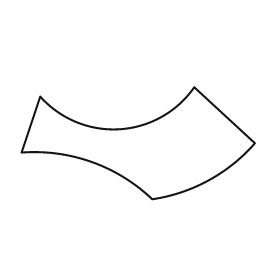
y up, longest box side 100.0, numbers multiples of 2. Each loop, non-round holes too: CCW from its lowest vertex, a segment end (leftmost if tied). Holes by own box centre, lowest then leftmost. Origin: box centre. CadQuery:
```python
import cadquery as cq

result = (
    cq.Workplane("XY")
    .moveTo(6.0, -24.0)
    .threePointArc((30.0, -16.0), (50.0, 0.0))
    .lineTo(24.0, 24.0)
    .threePointArc((-8.0, 6.0), (-42.0, 20.0))
    .lineTo(-50.0, -4.0)
    .threePointArc((-20.0, -8.0), (6.0, -24.0))
    .close()
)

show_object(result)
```